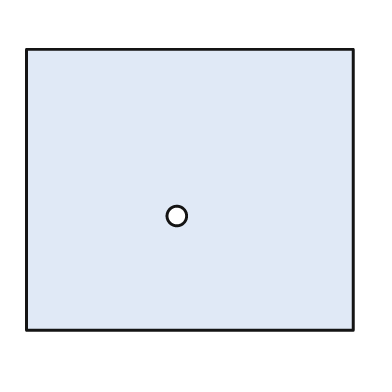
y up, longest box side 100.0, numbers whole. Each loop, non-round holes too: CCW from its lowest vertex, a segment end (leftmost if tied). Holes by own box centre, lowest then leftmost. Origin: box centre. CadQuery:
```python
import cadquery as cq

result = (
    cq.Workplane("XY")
    .moveTo(-50.0, -43.0)
    .lineTo(50.0, -43.0)
    .lineTo(50.0, 43.0)
    .lineTo(-50.0, 43.0)
    .close()
    .moveTo(-4.0, -8.0)
    .circle(3.0)
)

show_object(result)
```